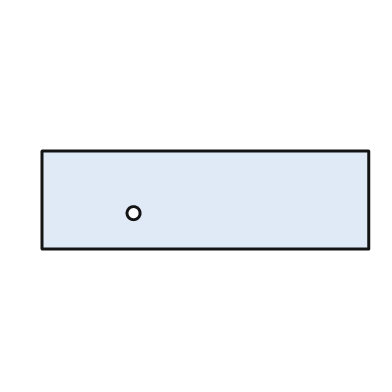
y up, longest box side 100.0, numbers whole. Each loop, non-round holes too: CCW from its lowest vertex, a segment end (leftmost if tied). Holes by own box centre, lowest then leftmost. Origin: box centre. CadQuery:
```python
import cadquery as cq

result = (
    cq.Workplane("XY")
    .moveTo(-50.0, -15.0)
    .lineTo(50.0, -15.0)
    .lineTo(50.0, 15.0)
    .lineTo(-50.0, 15.0)
    .close()
    .moveTo(-22.0, -4.0)
    .circle(2.0)
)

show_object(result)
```